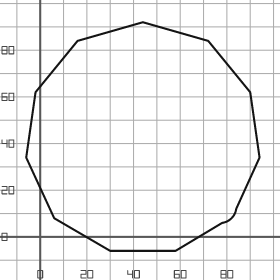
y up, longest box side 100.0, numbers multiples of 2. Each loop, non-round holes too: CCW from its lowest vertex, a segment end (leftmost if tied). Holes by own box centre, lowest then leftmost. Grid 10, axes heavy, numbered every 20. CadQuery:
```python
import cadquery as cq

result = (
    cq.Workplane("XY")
    .moveTo(30.0, -6.0)
    .lineTo(58.0, -6.0)
    .lineTo(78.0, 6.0)
    .threePointArc((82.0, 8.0), (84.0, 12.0))
    .lineTo(94.0, 34.0)
    .lineTo(90.0, 62.0)
    .lineTo(72.0, 84.0)
    .lineTo(44.0, 92.0)
    .lineTo(16.0, 84.0)
    .lineTo(-2.0, 62.0)
    .lineTo(-6.0, 34.0)
    .lineTo(6.0, 8.0)
    .close()
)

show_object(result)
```